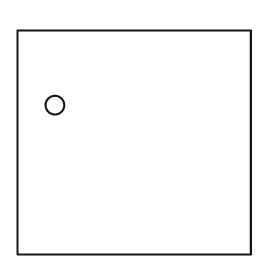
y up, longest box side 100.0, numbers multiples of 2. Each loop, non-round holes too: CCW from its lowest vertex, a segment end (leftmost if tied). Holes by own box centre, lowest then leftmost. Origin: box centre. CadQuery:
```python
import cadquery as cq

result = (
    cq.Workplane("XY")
    .moveTo(-50.0, -48.0)
    .lineTo(50.0, -48.0)
    .lineTo(50.0, 48.0)
    .lineTo(-50.0, 48.0)
    .close()
    .moveTo(-34.0, 16.0)
    .circle(4.0)
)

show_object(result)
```